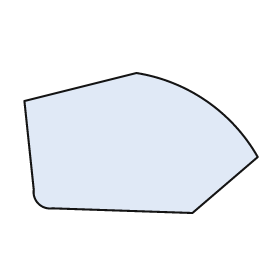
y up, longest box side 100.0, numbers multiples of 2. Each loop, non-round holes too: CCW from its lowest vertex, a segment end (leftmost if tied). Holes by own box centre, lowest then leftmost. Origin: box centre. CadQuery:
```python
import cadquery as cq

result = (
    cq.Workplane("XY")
    .moveTo(22.0, -30.0)
    .lineTo(50.0, -6.0)
    .threePointArc((28.0, 18.0), (-2.0, 30.0))
    .lineTo(-50.0, 18.0)
    .lineTo(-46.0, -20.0)
    .threePointArc((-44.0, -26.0), (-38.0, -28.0))
    .close()
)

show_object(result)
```